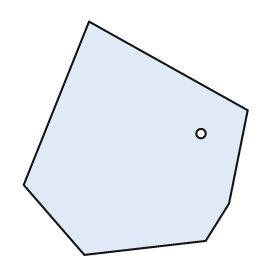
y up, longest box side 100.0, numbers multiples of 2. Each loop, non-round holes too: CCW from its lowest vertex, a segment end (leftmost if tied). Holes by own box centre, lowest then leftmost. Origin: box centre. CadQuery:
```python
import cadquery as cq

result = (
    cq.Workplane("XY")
    .moveTo(-22.0, -50.0)
    .lineTo(30.0, -44.0)
    .lineTo(40.0, -28.0)
    .lineTo(48.0, 12.0)
    .lineTo(-20.0, 50.0)
    .lineTo(-48.0, -20.0)
    .close()
    .moveTo(28.0, 2.0)
    .circle(2.0)
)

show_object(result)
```